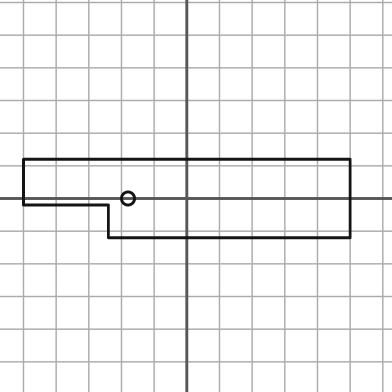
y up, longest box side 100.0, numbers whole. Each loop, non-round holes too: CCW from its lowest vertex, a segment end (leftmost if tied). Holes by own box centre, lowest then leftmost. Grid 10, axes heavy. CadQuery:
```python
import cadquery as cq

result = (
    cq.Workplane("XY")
    .moveTo(-24.0, -12.0)
    .lineTo(50.0, -12.0)
    .lineTo(50.0, 12.0)
    .lineTo(-50.0, 12.0)
    .lineTo(-50.0, -2.0)
    .lineTo(-24.0, -2.0)
    .close()
    .moveTo(-18.0, 0.0)
    .circle(2.0)
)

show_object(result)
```